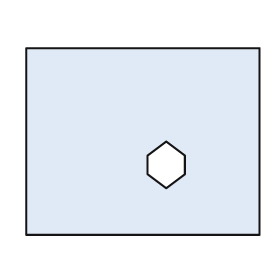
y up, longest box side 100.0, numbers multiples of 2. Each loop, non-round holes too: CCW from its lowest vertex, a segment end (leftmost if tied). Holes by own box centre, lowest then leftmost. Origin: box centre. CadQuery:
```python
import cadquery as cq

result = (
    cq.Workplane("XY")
    .moveTo(-50.0, -40.0)
    .lineTo(50.0, -40.0)
    .lineTo(50.0, 40.0)
    .lineTo(-50.0, 40.0)
    .close()
    .moveTo(10.0, -20.0)
    .lineTo(18.0, -14.0)
    .lineTo(18.0, -6.0)
    .lineTo(10.0, 0.0)
    .lineTo(2.0, -6.0)
    .lineTo(2.0, -14.0)
    .close()
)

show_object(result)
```